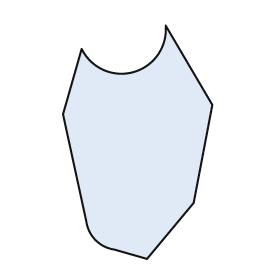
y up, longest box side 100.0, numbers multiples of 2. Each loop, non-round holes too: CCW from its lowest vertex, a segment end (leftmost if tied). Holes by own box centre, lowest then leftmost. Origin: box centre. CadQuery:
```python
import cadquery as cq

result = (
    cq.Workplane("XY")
    .moveTo(4.0, -50.0)
    .lineTo(24.0, -26.0)
    .lineTo(32.0, 16.0)
    .lineTo(12.0, 50.0)
    .threePointArc((-2.0, 30.0), (-24.0, 40.0))
    .lineTo(-32.0, 12.0)
    .lineTo(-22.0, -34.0)
    .threePointArc((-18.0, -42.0), (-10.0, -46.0))
    .close()
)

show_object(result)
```